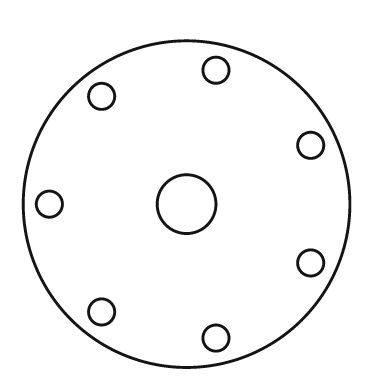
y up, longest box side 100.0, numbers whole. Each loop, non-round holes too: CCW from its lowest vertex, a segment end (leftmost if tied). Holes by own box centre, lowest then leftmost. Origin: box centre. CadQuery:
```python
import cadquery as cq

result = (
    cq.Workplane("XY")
    .moveTo(0.0, 0.0)
    .circle(50.0)
    .moveTo(9.0, -41.0)
    .circle(4.0)
    .moveTo(-26.0, -33.0)
    .circle(4.0)
    .moveTo(38.0, -18.0)
    .circle(4.0)
    .moveTo(-42.0, 0.0)
    .circle(4.0)
    .moveTo(0.0, 0.0)
    .circle(9.0)
    .moveTo(38.0, 18.0)
    .circle(4.0)
    .moveTo(-26.0, 33.0)
    .circle(4.0)
    .moveTo(9.0, 41.0)
    .circle(4.0)
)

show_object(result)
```